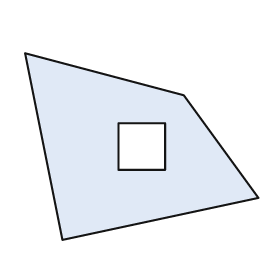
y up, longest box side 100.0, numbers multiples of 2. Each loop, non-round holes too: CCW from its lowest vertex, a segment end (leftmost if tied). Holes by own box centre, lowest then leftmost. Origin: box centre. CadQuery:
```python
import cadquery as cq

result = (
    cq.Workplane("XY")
    .moveTo(-34.0, -40.0)
    .lineTo(50.0, -22.0)
    .lineTo(18.0, 22.0)
    .lineTo(-50.0, 40.0)
    .close()
    .moveTo(-10.0, -10.0)
    .lineTo(10.0, -10.0)
    .lineTo(10.0, 10.0)
    .lineTo(-10.0, 10.0)
    .close()
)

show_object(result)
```